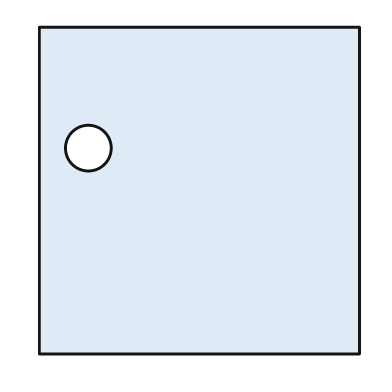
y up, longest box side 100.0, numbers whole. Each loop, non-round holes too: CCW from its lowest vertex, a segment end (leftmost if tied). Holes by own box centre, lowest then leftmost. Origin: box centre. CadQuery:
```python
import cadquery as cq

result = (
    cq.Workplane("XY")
    .moveTo(-49.0, -50.0)
    .lineTo(49.0, -50.0)
    .lineTo(49.0, 50.0)
    .lineTo(-49.0, 50.0)
    .close()
    .moveTo(-34.0, 13.0)
    .circle(7.0)
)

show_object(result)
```